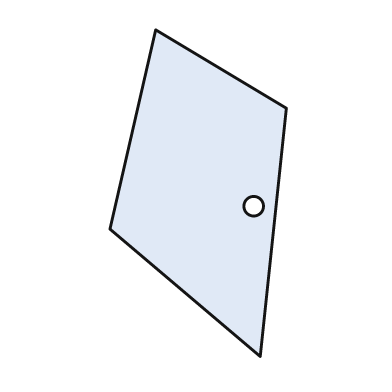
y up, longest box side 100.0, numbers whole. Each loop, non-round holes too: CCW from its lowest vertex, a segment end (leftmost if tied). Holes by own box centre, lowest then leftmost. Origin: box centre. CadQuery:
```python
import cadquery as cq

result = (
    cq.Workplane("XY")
    .moveTo(19.0, -50.0)
    .lineTo(27.0, 26.0)
    .lineTo(-13.0, 50.0)
    .lineTo(-27.0, -11.0)
    .close()
    .moveTo(17.0, -4.0)
    .circle(3.0)
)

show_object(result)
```